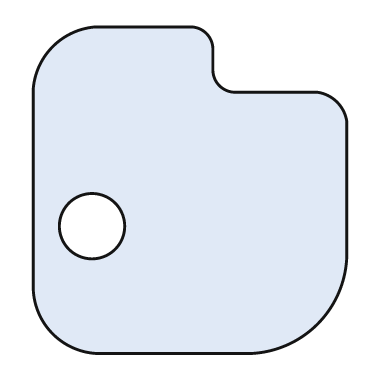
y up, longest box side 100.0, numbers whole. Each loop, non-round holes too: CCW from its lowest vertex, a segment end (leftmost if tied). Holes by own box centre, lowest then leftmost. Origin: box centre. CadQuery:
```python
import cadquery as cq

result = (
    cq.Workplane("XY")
    .moveTo(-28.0, -50.0)
    .lineTo(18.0, -50.0)
    .threePointArc((39.0, -41.0), (48.0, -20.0))
    .lineTo(48.0, 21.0)
    .threePointArc((45.0, 27.0), (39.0, 30.0))
    .lineTo(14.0, 30.0)
    .threePointArc((9.0, 32.0), (7.0, 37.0))
    .lineTo(7.0, 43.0)
    .threePointArc((5.0, 48.0), (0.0, 50.0))
    .lineTo(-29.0, 50.0)
    .threePointArc((-42.0, 44.0), (-48.0, 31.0))
    .lineTo(-48.0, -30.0)
    .threePointArc((-42.0, -44.0), (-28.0, -50.0))
    .close()
    .moveTo(-30.0, -11.0)
    .circle(10.0)
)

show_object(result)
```